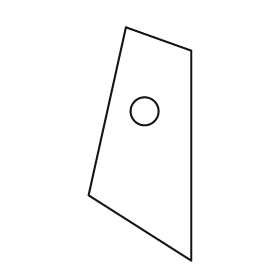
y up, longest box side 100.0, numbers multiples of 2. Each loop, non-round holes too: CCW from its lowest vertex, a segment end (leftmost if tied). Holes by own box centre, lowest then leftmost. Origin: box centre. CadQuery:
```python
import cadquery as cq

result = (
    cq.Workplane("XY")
    .moveTo(22.0, -50.0)
    .lineTo(22.0, 40.0)
    .lineTo(-6.0, 50.0)
    .lineTo(-22.0, -22.0)
    .close()
    .moveTo(2.0, 14.0)
    .circle(6.0)
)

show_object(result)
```